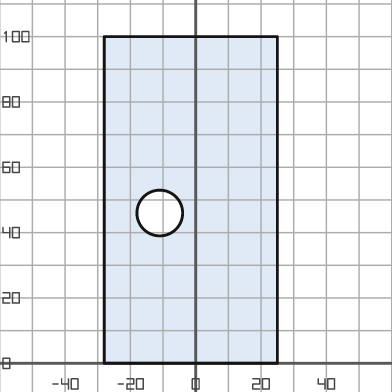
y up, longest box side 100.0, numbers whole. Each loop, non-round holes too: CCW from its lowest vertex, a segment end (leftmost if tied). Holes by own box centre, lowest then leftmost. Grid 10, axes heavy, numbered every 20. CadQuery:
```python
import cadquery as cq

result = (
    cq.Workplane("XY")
    .moveTo(-28.0, 0.0)
    .lineTo(25.0, 0.0)
    .lineTo(25.0, 100.0)
    .lineTo(-28.0, 100.0)
    .close()
    .moveTo(-11.0, 46.0)
    .circle(7.0)
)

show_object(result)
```